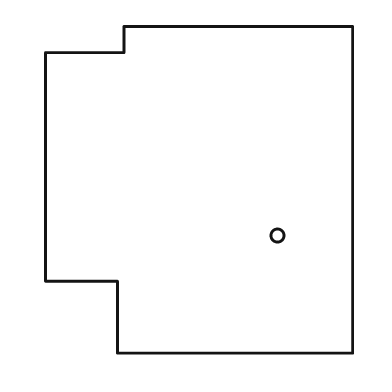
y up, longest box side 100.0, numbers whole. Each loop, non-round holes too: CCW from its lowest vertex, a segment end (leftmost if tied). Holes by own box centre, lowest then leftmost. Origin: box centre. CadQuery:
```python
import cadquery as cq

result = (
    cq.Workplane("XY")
    .moveTo(-25.0, -50.0)
    .lineTo(47.0, -50.0)
    .lineTo(47.0, 50.0)
    .lineTo(-23.0, 50.0)
    .lineTo(-23.0, 42.0)
    .lineTo(-47.0, 42.0)
    .lineTo(-47.0, -28.0)
    .lineTo(-25.0, -28.0)
    .close()
    .moveTo(24.0, -14.0)
    .circle(2.0)
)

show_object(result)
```